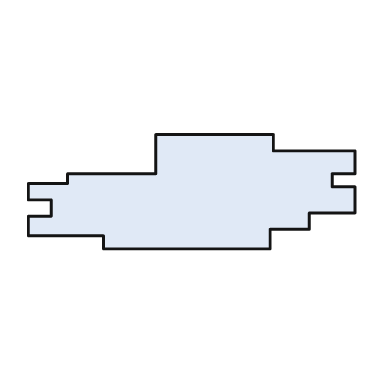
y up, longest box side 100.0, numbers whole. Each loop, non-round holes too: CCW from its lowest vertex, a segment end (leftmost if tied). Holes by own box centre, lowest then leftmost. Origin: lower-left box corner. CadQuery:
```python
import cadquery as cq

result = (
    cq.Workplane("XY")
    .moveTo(23.0, 0.0)
    .lineTo(74.0, 0.0)
    .lineTo(74.0, 6.0)
    .lineTo(86.0, 6.0)
    .lineTo(86.0, 11.0)
    .lineTo(100.0, 11.0)
    .lineTo(100.0, 19.0)
    .lineTo(93.0, 19.0)
    .lineTo(93.0, 23.0)
    .lineTo(100.0, 23.0)
    .lineTo(100.0, 30.0)
    .lineTo(75.0, 30.0)
    .lineTo(75.0, 35.0)
    .lineTo(39.0, 35.0)
    .lineTo(39.0, 23.0)
    .lineTo(12.0, 23.0)
    .lineTo(12.0, 20.0)
    .lineTo(0.0, 20.0)
    .lineTo(0.0, 15.0)
    .lineTo(7.0, 15.0)
    .lineTo(7.0, 10.0)
    .lineTo(0.0, 10.0)
    .lineTo(0.0, 4.0)
    .lineTo(23.0, 4.0)
    .close()
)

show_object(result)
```